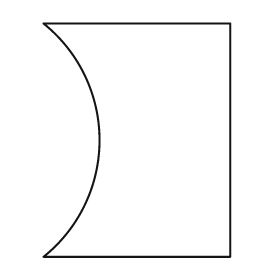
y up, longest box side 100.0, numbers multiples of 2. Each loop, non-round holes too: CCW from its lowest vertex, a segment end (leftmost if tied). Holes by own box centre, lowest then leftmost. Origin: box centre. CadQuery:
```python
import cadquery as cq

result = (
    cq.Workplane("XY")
    .moveTo(-40.0, -50.0)
    .lineTo(40.0, -50.0)
    .lineTo(40.0, 50.0)
    .lineTo(-40.0, 50.0)
    .threePointArc((-16.0, 0.0), (-40.0, -50.0))
    .close()
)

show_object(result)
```